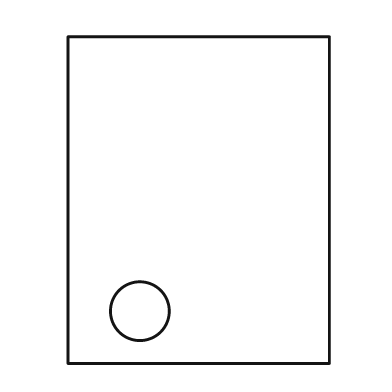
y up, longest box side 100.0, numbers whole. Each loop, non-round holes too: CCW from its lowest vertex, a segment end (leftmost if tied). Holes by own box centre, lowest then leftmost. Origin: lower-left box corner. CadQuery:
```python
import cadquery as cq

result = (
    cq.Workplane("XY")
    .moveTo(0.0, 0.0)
    .lineTo(80.0, 0.0)
    .lineTo(80.0, 100.0)
    .lineTo(0.0, 100.0)
    .close()
    .moveTo(22.0, 16.0)
    .circle(9.0)
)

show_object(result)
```